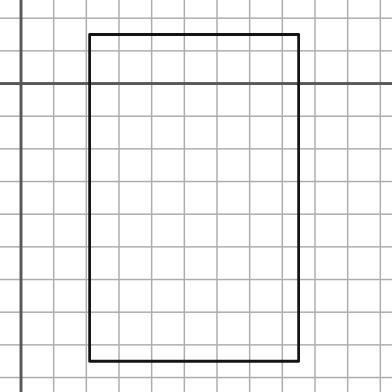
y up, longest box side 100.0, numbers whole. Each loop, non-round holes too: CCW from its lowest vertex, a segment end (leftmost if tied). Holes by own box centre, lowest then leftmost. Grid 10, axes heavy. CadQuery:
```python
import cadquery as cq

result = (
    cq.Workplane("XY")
    .moveTo(21.0, -85.0)
    .lineTo(85.0, -85.0)
    .lineTo(85.0, 15.0)
    .lineTo(21.0, 15.0)
    .close()
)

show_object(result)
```